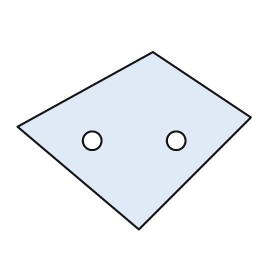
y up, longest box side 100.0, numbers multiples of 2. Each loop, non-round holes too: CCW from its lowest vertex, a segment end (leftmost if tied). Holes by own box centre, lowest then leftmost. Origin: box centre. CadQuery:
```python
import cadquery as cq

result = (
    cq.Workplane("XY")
    .moveTo(2.0, -38.0)
    .lineTo(50.0, 10.0)
    .lineTo(8.0, 38.0)
    .lineTo(-50.0, 6.0)
    .close()
    .moveTo(-18.0, 0.0)
    .circle(4.0)
    .moveTo(18.0, 0.0)
    .circle(4.0)
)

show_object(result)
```